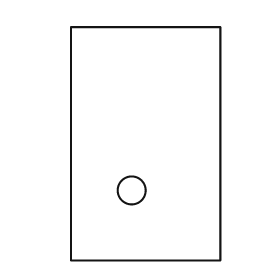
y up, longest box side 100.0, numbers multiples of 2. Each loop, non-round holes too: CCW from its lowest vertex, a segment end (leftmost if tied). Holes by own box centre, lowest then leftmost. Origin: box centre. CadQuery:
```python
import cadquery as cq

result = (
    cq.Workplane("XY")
    .moveTo(-32.0, -50.0)
    .lineTo(32.0, -50.0)
    .lineTo(32.0, 50.0)
    .lineTo(-32.0, 50.0)
    .close()
    .moveTo(-6.0, -20.0)
    .circle(6.0)
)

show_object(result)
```